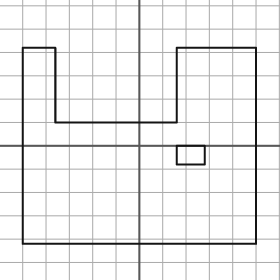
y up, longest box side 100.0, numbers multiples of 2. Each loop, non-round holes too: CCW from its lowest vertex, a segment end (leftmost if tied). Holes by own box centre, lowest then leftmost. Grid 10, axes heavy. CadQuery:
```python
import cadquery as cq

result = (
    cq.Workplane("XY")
    .moveTo(-50.0, -42.0)
    .lineTo(50.0, -42.0)
    .lineTo(50.0, 42.0)
    .lineTo(16.0, 42.0)
    .lineTo(16.0, 10.0)
    .lineTo(-36.0, 10.0)
    .lineTo(-36.0, 42.0)
    .lineTo(-50.0, 42.0)
    .close()
    .moveTo(16.0, -8.0)
    .lineTo(28.0, -8.0)
    .lineTo(28.0, 0.0)
    .lineTo(16.0, 0.0)
    .close()
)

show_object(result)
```